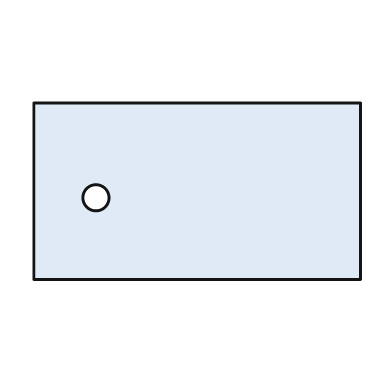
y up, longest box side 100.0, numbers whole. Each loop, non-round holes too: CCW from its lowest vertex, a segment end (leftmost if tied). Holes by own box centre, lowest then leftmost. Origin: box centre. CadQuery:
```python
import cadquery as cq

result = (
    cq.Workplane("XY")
    .moveTo(-50.0, -27.0)
    .lineTo(50.0, -27.0)
    .lineTo(50.0, 27.0)
    .lineTo(-50.0, 27.0)
    .close()
    .moveTo(-31.0, -2.0)
    .circle(4.0)
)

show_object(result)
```